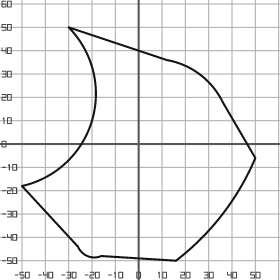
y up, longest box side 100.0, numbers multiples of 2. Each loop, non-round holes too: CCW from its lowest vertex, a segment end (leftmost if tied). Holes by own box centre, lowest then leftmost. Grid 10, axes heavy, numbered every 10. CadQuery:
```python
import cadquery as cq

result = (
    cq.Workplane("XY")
    .moveTo(16.0, -50.0)
    .threePointArc((36.0, -30.0), (50.0, -6.0))
    .lineTo(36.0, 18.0)
    .threePointArc((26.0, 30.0), (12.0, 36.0))
    .lineTo(-30.0, 50.0)
    .threePointArc((-20.0, 10.0), (-50.0, -18.0))
    .lineTo(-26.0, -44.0)
    .threePointArc((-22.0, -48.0), (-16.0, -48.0))
    .close()
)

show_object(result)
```